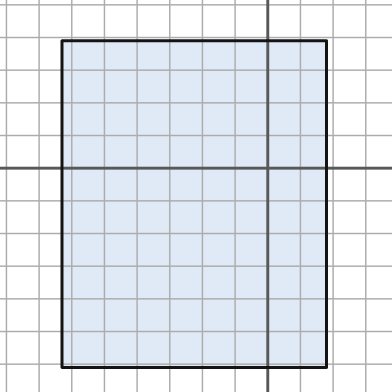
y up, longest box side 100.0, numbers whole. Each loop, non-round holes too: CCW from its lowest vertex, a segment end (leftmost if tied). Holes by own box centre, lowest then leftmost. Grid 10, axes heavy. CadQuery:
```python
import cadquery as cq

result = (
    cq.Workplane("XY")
    .moveTo(-63.0, -61.0)
    .lineTo(18.0, -61.0)
    .lineTo(18.0, 39.0)
    .lineTo(-63.0, 39.0)
    .close()
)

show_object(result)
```